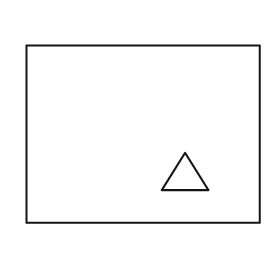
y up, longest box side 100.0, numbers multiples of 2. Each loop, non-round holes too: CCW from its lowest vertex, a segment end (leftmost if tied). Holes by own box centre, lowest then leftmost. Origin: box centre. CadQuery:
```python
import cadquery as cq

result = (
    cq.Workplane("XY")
    .moveTo(-50.0, -38.0)
    .lineTo(50.0, -38.0)
    .lineTo(50.0, 38.0)
    .lineTo(-50.0, 38.0)
    .close()
    .moveTo(8.0, -24.0)
    .lineTo(28.0, -24.0)
    .lineTo(18.0, -8.0)
    .close()
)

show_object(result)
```